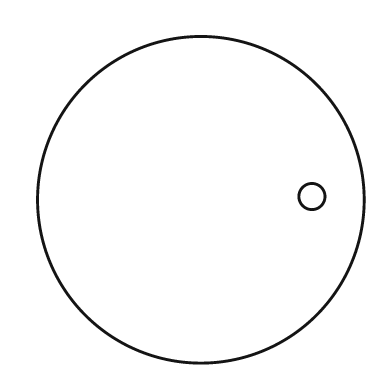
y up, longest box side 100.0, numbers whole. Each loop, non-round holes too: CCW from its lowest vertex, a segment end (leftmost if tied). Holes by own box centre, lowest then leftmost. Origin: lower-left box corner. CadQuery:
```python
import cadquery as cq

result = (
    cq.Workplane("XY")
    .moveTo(50.0, 50.0)
    .circle(50.0)
    .moveTo(84.0, 51.0)
    .circle(4.0)
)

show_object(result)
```